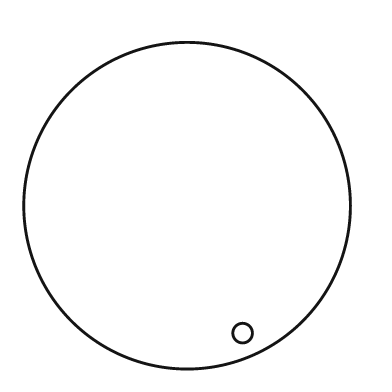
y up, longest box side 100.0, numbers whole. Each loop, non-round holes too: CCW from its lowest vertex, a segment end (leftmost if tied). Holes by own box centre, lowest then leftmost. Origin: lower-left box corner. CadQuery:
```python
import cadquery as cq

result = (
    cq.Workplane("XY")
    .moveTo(50.0, 50.0)
    .circle(50.0)
    .moveTo(67.0, 11.0)
    .circle(3.0)
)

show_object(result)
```